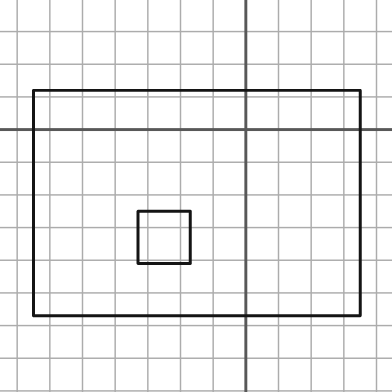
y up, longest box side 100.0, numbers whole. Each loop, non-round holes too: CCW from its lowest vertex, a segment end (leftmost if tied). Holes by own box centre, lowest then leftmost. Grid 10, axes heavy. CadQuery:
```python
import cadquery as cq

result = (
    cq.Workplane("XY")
    .moveTo(-65.0, -57.0)
    .lineTo(35.0, -57.0)
    .lineTo(35.0, 12.0)
    .lineTo(-65.0, 12.0)
    .close()
    .moveTo(-33.0, -41.0)
    .lineTo(-17.0, -41.0)
    .lineTo(-17.0, -25.0)
    .lineTo(-33.0, -25.0)
    .close()
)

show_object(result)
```